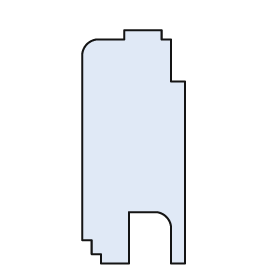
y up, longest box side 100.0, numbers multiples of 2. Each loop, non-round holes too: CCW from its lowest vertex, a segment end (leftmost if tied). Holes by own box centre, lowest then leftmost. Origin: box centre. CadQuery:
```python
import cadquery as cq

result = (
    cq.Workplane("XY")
    .moveTo(-14.0, -50.0)
    .lineTo(-2.0, -50.0)
    .lineTo(-2.0, -28.0)
    .lineTo(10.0, -28.0)
    .threePointArc((14.0, -30.0), (16.0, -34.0))
    .lineTo(16.0, -50.0)
    .lineTo(22.0, -50.0)
    .lineTo(22.0, 28.0)
    .lineTo(16.0, 28.0)
    .lineTo(16.0, 46.0)
    .lineTo(12.0, 46.0)
    .lineTo(12.0, 50.0)
    .lineTo(-4.0, 50.0)
    .lineTo(-4.0, 46.0)
    .lineTo(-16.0, 46.0)
    .threePointArc((-20.0, 44.0), (-22.0, 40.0))
    .lineTo(-22.0, -40.0)
    .lineTo(-18.0, -40.0)
    .lineTo(-18.0, -46.0)
    .lineTo(-14.0, -46.0)
    .close()
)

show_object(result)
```